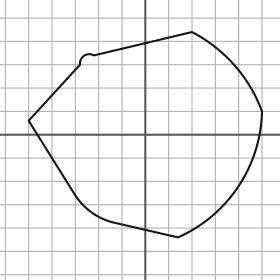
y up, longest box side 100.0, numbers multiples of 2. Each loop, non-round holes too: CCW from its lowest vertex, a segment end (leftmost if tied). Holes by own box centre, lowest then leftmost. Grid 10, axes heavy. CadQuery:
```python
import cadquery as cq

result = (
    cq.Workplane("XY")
    .moveTo(14.0, -44.0)
    .threePointArc((40.0, -22.0), (50.0, 10.0))
    .threePointArc((38.0, 30.0), (20.0, 44.0))
    .lineTo(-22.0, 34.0)
    .threePointArc((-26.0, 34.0), (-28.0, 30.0))
    .lineTo(-50.0, 6.0)
    .lineTo(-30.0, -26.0)
    .threePointArc((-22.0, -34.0), (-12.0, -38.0))
    .close()
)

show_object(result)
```